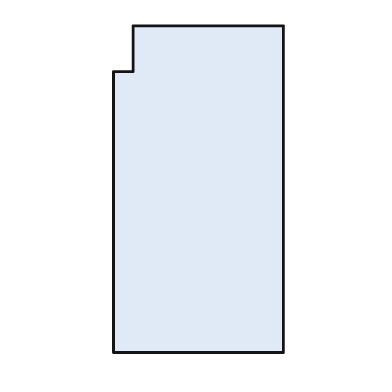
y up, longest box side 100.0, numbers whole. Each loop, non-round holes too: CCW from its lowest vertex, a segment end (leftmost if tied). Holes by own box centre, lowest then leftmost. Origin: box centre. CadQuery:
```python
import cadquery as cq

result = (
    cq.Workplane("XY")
    .moveTo(-26.0, -50.0)
    .lineTo(26.0, -50.0)
    .lineTo(26.0, 50.0)
    .lineTo(-20.0, 50.0)
    .lineTo(-20.0, 36.0)
    .lineTo(-26.0, 36.0)
    .close()
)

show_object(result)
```